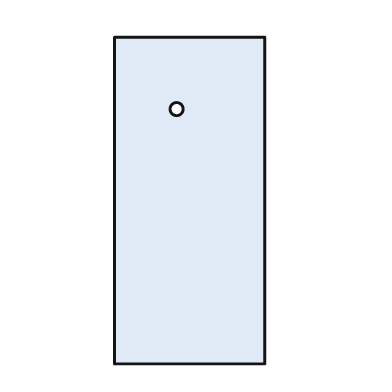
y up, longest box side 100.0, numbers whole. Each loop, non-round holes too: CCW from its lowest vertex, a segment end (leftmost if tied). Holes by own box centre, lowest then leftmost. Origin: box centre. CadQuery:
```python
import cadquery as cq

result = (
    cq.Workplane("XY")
    .moveTo(-23.0, -50.0)
    .lineTo(23.0, -50.0)
    .lineTo(23.0, 50.0)
    .lineTo(-23.0, 50.0)
    .close()
    .moveTo(-4.0, 28.0)
    .circle(2.0)
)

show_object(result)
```